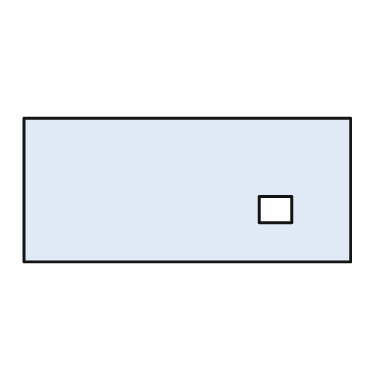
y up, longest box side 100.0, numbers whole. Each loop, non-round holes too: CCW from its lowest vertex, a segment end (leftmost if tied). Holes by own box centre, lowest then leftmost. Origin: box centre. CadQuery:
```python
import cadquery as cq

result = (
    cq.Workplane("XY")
    .moveTo(-50.0, -22.0)
    .lineTo(50.0, -22.0)
    .lineTo(50.0, 22.0)
    .lineTo(-50.0, 22.0)
    .close()
    .moveTo(22.0, -10.0)
    .lineTo(32.0, -10.0)
    .lineTo(32.0, -2.0)
    .lineTo(22.0, -2.0)
    .close()
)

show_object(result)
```